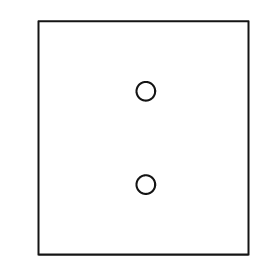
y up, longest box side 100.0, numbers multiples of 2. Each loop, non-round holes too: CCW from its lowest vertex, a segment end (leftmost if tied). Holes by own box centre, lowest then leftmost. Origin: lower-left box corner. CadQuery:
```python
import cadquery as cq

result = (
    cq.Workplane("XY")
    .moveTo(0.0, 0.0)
    .lineTo(90.0, 0.0)
    .lineTo(90.0, 100.0)
    .lineTo(0.0, 100.0)
    .close()
    .moveTo(46.0, 30.0)
    .circle(4.0)
    .moveTo(46.0, 70.0)
    .circle(4.0)
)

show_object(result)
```